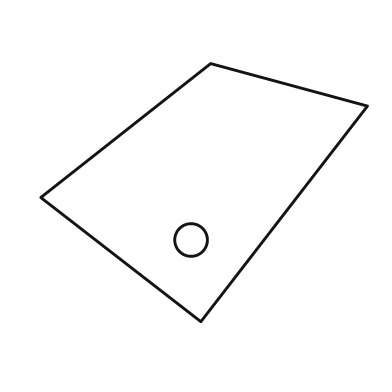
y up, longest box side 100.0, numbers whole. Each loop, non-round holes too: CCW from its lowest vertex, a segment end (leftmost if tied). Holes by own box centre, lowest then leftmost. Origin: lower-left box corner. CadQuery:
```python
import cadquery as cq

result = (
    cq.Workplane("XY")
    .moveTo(49.0, 0.0)
    .lineTo(100.0, 66.0)
    .lineTo(52.0, 79.0)
    .lineTo(0.0, 38.0)
    .close()
    .moveTo(46.0, 25.0)
    .circle(5.0)
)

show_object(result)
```